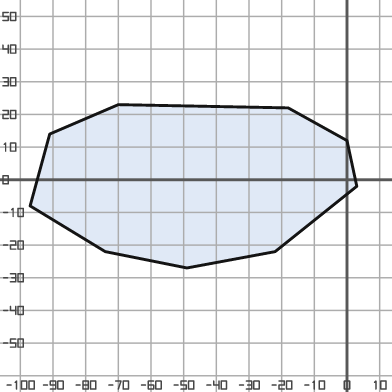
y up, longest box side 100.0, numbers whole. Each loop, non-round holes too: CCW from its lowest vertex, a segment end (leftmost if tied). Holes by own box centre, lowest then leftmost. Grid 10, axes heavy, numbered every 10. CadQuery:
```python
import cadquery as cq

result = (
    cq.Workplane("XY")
    .moveTo(-49.0, -27.0)
    .lineTo(-22.0, -22.0)
    .lineTo(3.0, -2.0)
    .lineTo(0.0, 12.0)
    .lineTo(-18.0, 22.0)
    .lineTo(-70.0, 23.0)
    .lineTo(-91.0, 14.0)
    .lineTo(-97.0, -8.0)
    .lineTo(-74.0, -22.0)
    .close()
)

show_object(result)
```